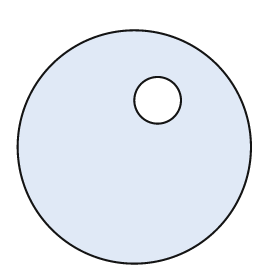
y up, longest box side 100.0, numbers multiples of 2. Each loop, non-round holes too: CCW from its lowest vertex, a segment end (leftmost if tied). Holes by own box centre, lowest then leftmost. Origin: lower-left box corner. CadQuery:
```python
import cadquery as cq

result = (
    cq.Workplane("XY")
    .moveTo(50.0, 50.0)
    .circle(50.0)
    .moveTo(60.0, 70.0)
    .circle(10.0)
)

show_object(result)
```